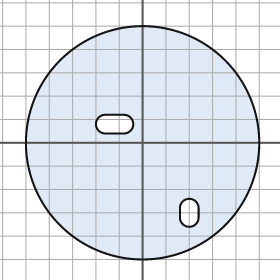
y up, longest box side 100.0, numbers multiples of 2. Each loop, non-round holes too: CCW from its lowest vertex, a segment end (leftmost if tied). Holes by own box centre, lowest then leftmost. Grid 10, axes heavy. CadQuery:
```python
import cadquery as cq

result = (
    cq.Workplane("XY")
    .moveTo(0.0, 0.0)
    .circle(50.0)
    .moveTo(16.0, -32.0)
    .threePointArc((20.0, -36.0), (24.0, -32.0))
    .lineTo(24.0, -28.0)
    .threePointArc((20.0, -24.0), (16.0, -28.0))
    .close()
    .moveTo(-16.0, 4.0)
    .lineTo(-8.0, 4.0)
    .threePointArc((-4.0, 8.0), (-8.0, 12.0))
    .lineTo(-16.0, 12.0)
    .threePointArc((-20.0, 8.0), (-16.0, 4.0))
    .close()
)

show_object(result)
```